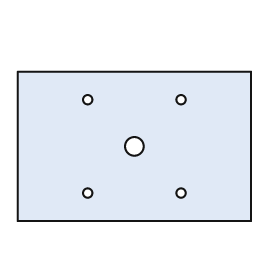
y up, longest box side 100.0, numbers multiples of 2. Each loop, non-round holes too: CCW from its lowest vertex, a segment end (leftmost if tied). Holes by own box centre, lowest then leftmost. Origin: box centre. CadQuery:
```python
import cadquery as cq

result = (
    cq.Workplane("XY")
    .moveTo(-50.0, -32.0)
    .lineTo(50.0, -32.0)
    .lineTo(50.0, 32.0)
    .lineTo(-50.0, 32.0)
    .close()
    .moveTo(-20.0, -20.0)
    .circle(2.0)
    .moveTo(20.0, -20.0)
    .circle(2.0)
    .moveTo(0.0, 0.0)
    .circle(4.0)
    .moveTo(-20.0, 20.0)
    .circle(2.0)
    .moveTo(20.0, 20.0)
    .circle(2.0)
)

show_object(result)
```